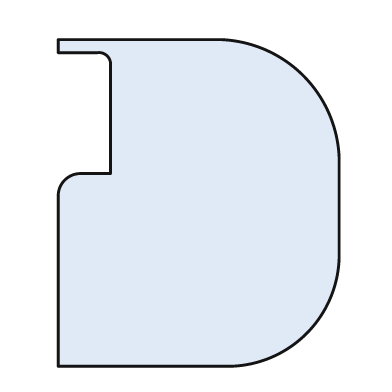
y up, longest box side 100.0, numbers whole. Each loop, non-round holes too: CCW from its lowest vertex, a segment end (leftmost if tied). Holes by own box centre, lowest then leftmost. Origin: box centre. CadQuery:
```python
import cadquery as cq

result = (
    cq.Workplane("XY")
    .moveTo(-43.0, -50.0)
    .lineTo(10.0, -50.0)
    .threePointArc((33.0, -40.0), (43.0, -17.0))
    .lineTo(43.0, 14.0)
    .threePointArc((32.0, 39.0), (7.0, 50.0))
    .lineTo(-43.0, 50.0)
    .lineTo(-43.0, 46.0)
    .lineTo(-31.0, 46.0)
    .threePointArc((-28.0, 45.0), (-27.0, 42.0))
    .lineTo(-27.0, 9.0)
    .lineTo(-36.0, 9.0)
    .threePointArc((-41.0, 7.0), (-43.0, 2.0))
    .close()
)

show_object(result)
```